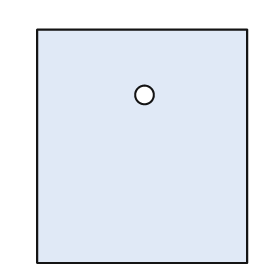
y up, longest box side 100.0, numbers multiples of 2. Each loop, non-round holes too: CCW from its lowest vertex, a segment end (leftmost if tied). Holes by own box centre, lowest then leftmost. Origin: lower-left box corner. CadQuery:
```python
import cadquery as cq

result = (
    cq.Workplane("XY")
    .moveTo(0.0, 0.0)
    .lineTo(90.0, 0.0)
    .lineTo(90.0, 100.0)
    .lineTo(0.0, 100.0)
    .close()
    .moveTo(46.0, 72.0)
    .circle(4.0)
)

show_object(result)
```